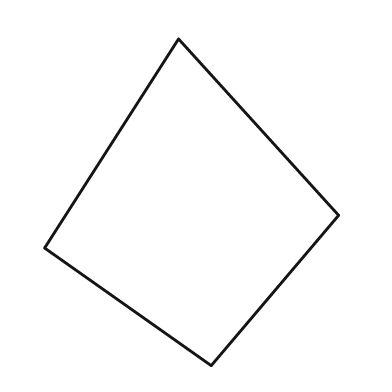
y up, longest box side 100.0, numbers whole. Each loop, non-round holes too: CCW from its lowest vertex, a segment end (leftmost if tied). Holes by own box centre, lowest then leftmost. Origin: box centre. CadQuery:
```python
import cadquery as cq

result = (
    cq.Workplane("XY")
    .moveTo(6.0, -50.0)
    .lineTo(45.0, -4.0)
    .lineTo(-4.0, 50.0)
    .lineTo(-45.0, -14.0)
    .close()
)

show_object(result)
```